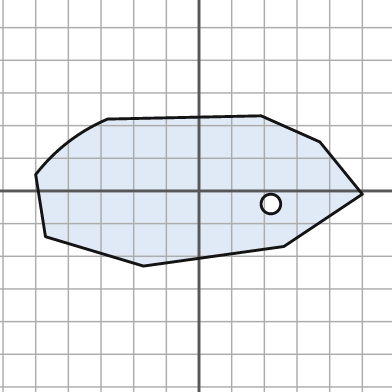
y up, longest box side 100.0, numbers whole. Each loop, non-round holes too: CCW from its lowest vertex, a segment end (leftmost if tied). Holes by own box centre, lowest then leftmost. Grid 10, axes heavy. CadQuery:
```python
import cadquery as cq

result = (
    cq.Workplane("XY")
    .moveTo(-17.0, -23.0)
    .lineTo(26.0, -17.0)
    .lineTo(50.0, -1.0)
    .lineTo(37.0, 15.0)
    .lineTo(19.0, 23.0)
    .lineTo(-28.0, 22.0)
    .threePointArc((-40.0, 15.0), (-50.0, 5.0))
    .lineTo(-47.0, -14.0)
    .close()
    .moveTo(22.0, -4.0)
    .circle(3.0)
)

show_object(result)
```